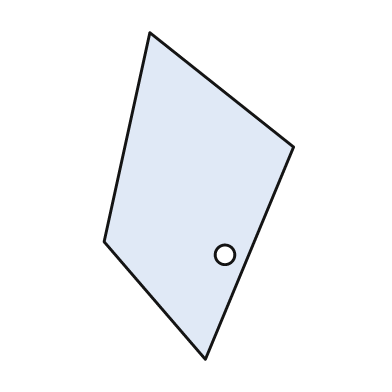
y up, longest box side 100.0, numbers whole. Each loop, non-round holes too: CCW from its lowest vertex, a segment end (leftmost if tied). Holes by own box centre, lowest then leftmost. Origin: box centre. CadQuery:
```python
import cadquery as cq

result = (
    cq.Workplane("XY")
    .moveTo(2.0, -50.0)
    .lineTo(29.0, 15.0)
    .lineTo(-15.0, 50.0)
    .lineTo(-29.0, -14.0)
    .close()
    .moveTo(8.0, -18.0)
    .circle(3.0)
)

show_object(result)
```